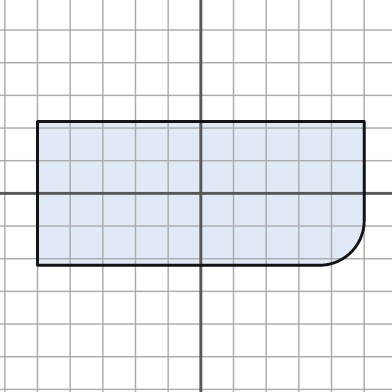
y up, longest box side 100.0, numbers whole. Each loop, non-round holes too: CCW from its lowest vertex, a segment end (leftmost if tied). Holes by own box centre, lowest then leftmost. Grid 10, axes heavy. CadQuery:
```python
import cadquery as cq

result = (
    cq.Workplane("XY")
    .moveTo(-50.0, -22.0)
    .lineTo(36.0, -22.0)
    .threePointArc((46.0, -18.0), (50.0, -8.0))
    .lineTo(50.0, 22.0)
    .lineTo(-50.0, 22.0)
    .close()
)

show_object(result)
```